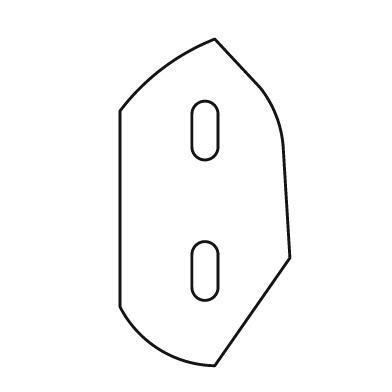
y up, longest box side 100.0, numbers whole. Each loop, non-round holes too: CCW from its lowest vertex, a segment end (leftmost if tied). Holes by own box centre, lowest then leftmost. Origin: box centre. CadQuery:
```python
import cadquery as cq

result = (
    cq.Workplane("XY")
    .moveTo(3.0, -50.0)
    .lineTo(26.0, -17.0)
    .lineTo(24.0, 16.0)
    .threePointArc((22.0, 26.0), (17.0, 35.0))
    .lineTo(3.0, 50.0)
    .threePointArc((-13.0, 41.0), (-26.0, 28.0))
    .lineTo(-26.0, -32.0)
    .threePointArc((-14.0, -45.0), (3.0, -50.0))
    .close()
    .moveTo(-4.0, -26.0)
    .threePointArc((0.0, -30.0), (4.0, -26.0))
    .lineTo(4.0, -16.0)
    .threePointArc((0.0, -12.0), (-4.0, -16.0))
    .close()
    .moveTo(-4.0, 17.0)
    .threePointArc((0.0, 13.0), (4.0, 17.0))
    .lineTo(4.0, 27.0)
    .threePointArc((0.0, 31.0), (-4.0, 27.0))
    .close()
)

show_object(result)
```